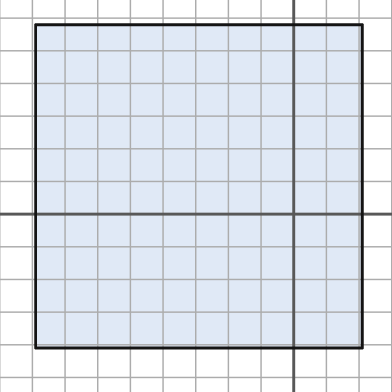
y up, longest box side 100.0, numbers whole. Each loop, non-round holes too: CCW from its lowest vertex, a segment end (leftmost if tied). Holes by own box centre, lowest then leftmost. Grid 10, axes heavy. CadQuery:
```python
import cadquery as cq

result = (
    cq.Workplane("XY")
    .moveTo(-79.0, -41.0)
    .lineTo(21.0, -41.0)
    .lineTo(21.0, 58.0)
    .lineTo(-79.0, 58.0)
    .close()
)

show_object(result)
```